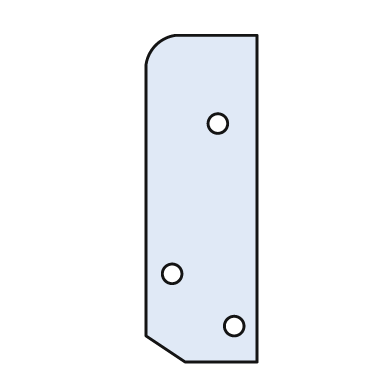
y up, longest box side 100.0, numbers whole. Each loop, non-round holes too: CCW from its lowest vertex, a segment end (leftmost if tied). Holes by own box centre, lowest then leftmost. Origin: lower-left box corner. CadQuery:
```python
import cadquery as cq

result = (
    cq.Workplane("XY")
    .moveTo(12.0, 0.0)
    .lineTo(34.0, 0.0)
    .lineTo(34.0, 100.0)
    .lineTo(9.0, 100.0)
    .threePointArc((3.0, 97.0), (0.0, 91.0))
    .lineTo(0.0, 8.0)
    .close()
    .moveTo(27.0, 11.0)
    .circle(3.0)
    .moveTo(8.0, 27.0)
    .circle(3.0)
    .moveTo(22.0, 73.0)
    .circle(3.0)
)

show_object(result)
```